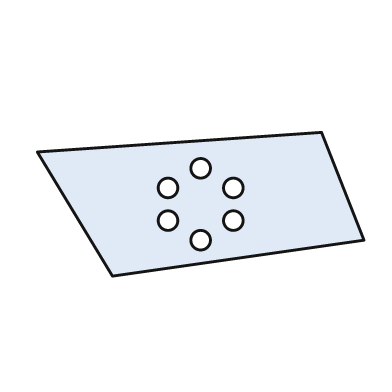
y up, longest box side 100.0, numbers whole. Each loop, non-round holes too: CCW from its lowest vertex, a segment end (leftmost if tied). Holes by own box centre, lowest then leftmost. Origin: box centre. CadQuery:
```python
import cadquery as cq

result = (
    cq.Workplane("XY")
    .moveTo(-27.0, -22.0)
    .lineTo(50.0, -11.0)
    .lineTo(37.0, 22.0)
    .lineTo(-50.0, 16.0)
    .close()
    .moveTo(0.0, -11.0)
    .circle(3.0)
    .moveTo(-10.0, -5.0)
    .circle(3.0)
    .moveTo(10.0, -5.0)
    .circle(3.0)
    .moveTo(-10.0, 5.0)
    .circle(3.0)
    .moveTo(10.0, 5.0)
    .circle(3.0)
    .moveTo(0.0, 11.0)
    .circle(3.0)
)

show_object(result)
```